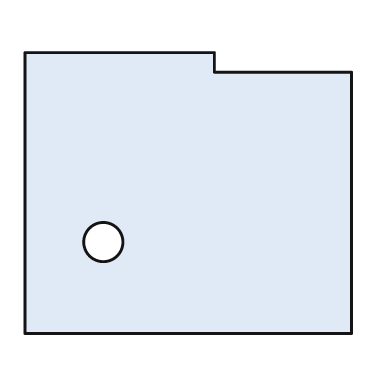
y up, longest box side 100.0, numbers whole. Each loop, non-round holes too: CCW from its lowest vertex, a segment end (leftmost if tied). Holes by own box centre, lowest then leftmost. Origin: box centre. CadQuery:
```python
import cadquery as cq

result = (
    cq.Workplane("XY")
    .moveTo(-50.0, -43.0)
    .lineTo(50.0, -43.0)
    .lineTo(50.0, 37.0)
    .lineTo(8.0, 37.0)
    .lineTo(8.0, 43.0)
    .lineTo(-50.0, 43.0)
    .close()
    .moveTo(-26.0, -15.0)
    .circle(6.0)
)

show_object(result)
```